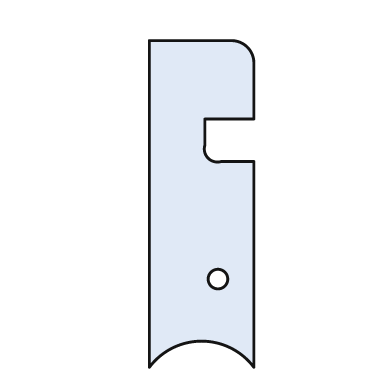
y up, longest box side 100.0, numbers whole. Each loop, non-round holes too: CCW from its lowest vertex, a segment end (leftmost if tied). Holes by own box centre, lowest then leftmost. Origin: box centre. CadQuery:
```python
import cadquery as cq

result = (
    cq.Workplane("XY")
    .moveTo(-16.0, -50.0)
    .threePointArc((0.0, -42.0), (16.0, -50.0))
    .lineTo(16.0, 13.0)
    .lineTo(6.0, 13.0)
    .threePointArc((2.0, 14.0), (1.0, 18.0))
    .lineTo(1.0, 26.0)
    .lineTo(16.0, 26.0)
    .lineTo(16.0, 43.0)
    .threePointArc((14.0, 48.0), (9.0, 50.0))
    .lineTo(-16.0, 50.0)
    .close()
    .moveTo(5.0, -23.0)
    .circle(3.0)
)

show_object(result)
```